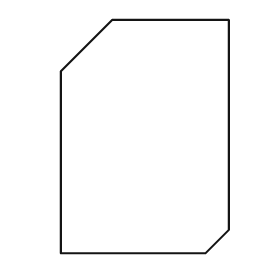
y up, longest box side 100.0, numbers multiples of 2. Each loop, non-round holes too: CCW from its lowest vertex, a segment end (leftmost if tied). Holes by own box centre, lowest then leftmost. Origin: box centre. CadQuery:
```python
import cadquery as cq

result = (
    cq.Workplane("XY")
    .moveTo(-36.0, -50.0)
    .lineTo(26.0, -50.0)
    .lineTo(36.0, -40.0)
    .lineTo(36.0, 50.0)
    .lineTo(-14.0, 50.0)
    .lineTo(-36.0, 28.0)
    .close()
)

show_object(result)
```